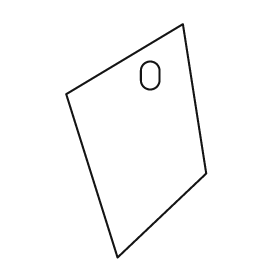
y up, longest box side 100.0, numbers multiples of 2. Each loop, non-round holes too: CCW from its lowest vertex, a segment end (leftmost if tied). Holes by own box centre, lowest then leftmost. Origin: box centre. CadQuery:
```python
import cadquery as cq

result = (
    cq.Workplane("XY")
    .moveTo(-8.0, -50.0)
    .lineTo(30.0, -14.0)
    .lineTo(20.0, 50.0)
    .lineTo(-30.0, 20.0)
    .close()
    .moveTo(2.0, 26.0)
    .threePointArc((6.0, 22.0), (10.0, 26.0))
    .lineTo(10.0, 30.0)
    .threePointArc((6.0, 34.0), (2.0, 30.0))
    .close()
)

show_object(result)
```